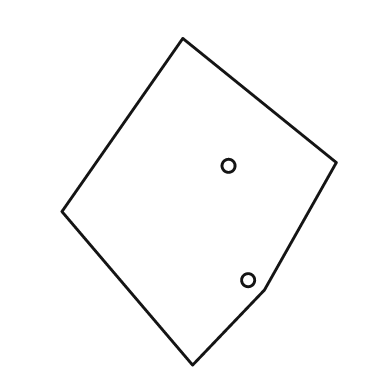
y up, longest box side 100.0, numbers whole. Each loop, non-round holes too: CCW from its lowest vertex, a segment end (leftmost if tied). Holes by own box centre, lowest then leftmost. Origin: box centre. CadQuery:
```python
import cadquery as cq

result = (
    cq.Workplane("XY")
    .moveTo(-2.0, -50.0)
    .lineTo(20.0, -27.0)
    .lineTo(42.0, 12.0)
    .lineTo(-5.0, 50.0)
    .lineTo(-42.0, -3.0)
    .close()
    .moveTo(15.0, -24.0)
    .circle(2.0)
    .moveTo(9.0, 11.0)
    .circle(2.0)
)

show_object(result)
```